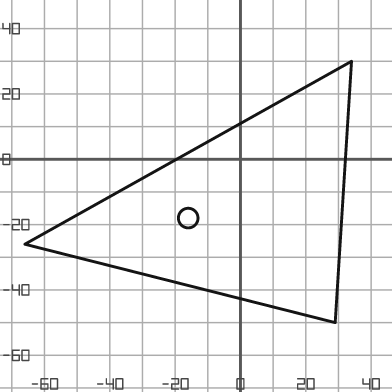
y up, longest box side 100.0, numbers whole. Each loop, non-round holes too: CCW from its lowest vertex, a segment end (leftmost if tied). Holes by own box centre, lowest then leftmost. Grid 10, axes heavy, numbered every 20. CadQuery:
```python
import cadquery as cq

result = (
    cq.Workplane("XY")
    .moveTo(29.0, -50.0)
    .lineTo(34.0, 30.0)
    .lineTo(-66.0, -26.0)
    .close()
    .moveTo(-16.0, -18.0)
    .circle(3.0)
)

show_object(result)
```